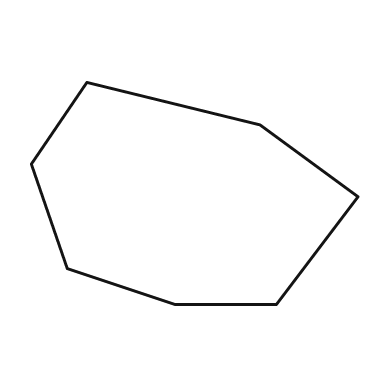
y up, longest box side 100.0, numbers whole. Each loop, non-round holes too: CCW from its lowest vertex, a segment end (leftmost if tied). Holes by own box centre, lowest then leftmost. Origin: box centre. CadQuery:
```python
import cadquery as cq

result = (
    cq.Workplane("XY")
    .moveTo(-6.0, -34.0)
    .lineTo(25.0, -34.0)
    .lineTo(50.0, -1.0)
    .lineTo(20.0, 21.0)
    .lineTo(-33.0, 34.0)
    .lineTo(-50.0, 9.0)
    .lineTo(-39.0, -23.0)
    .close()
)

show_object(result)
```